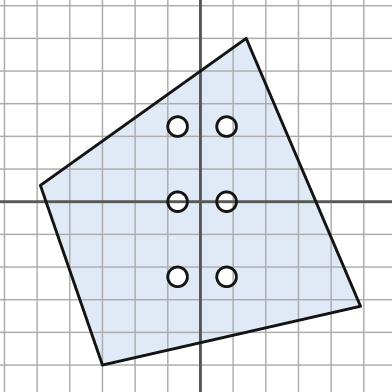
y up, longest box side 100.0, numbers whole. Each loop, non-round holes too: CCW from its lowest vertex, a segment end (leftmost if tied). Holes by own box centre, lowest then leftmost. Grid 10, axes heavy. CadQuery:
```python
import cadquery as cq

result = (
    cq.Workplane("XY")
    .moveTo(-30.0, -50.0)
    .lineTo(49.0, -32.0)
    .lineTo(14.0, 50.0)
    .lineTo(-49.0, 5.0)
    .close()
    .moveTo(-7.0, -23.0)
    .circle(3.0)
    .moveTo(8.0, -23.0)
    .circle(3.0)
    .moveTo(-7.0, 0.0)
    .circle(3.0)
    .moveTo(8.0, 0.0)
    .circle(3.0)
    .moveTo(-7.0, 23.0)
    .circle(3.0)
    .moveTo(8.0, 23.0)
    .circle(3.0)
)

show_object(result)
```